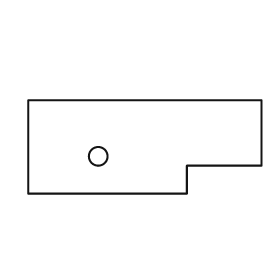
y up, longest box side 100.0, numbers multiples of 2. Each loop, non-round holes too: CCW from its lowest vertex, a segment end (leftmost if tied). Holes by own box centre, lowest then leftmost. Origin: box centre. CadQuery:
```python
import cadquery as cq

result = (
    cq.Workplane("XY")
    .moveTo(-50.0, -20.0)
    .lineTo(18.0, -20.0)
    .lineTo(18.0, -8.0)
    .lineTo(50.0, -8.0)
    .lineTo(50.0, 20.0)
    .lineTo(-50.0, 20.0)
    .close()
    .moveTo(-20.0, -4.0)
    .circle(4.0)
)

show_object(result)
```